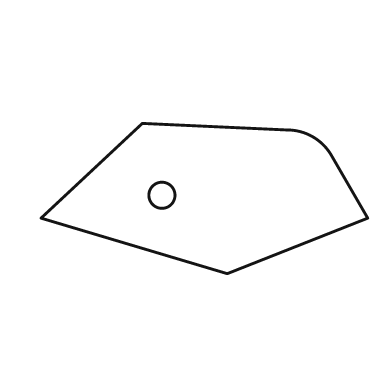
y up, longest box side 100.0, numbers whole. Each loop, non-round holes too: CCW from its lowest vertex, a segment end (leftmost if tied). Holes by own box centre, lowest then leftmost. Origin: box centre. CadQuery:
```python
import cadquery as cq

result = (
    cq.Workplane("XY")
    .moveTo(7.0, -23.0)
    .lineTo(50.0, -6.0)
    .lineTo(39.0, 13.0)
    .threePointArc((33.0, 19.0), (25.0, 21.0))
    .lineTo(-19.0, 23.0)
    .lineTo(-50.0, -6.0)
    .close()
    .moveTo(-13.0, 1.0)
    .circle(4.0)
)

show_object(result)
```